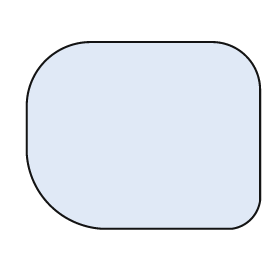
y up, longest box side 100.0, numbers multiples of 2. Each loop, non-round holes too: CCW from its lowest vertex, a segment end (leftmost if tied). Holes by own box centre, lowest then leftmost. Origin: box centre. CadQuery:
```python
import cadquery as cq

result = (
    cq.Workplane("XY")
    .moveTo(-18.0, -40.0)
    .lineTo(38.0, -40.0)
    .threePointArc((46.0, -36.0), (50.0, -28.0))
    .lineTo(50.0, 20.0)
    .threePointArc((44.0, 34.0), (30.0, 40.0))
    .lineTo(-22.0, 40.0)
    .threePointArc((-42.0, 32.0), (-50.0, 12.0))
    .lineTo(-50.0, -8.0)
    .threePointArc((-40.0, -30.0), (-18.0, -40.0))
    .close()
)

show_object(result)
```